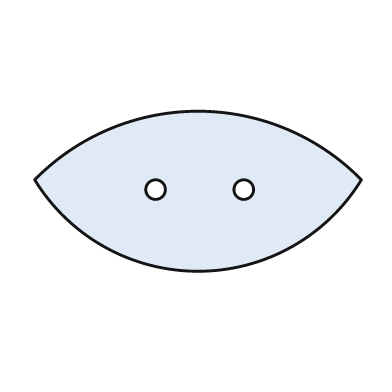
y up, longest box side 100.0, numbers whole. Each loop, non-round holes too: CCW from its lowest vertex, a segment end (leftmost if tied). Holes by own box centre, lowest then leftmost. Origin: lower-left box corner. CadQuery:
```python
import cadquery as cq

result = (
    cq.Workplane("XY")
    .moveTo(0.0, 28.0)
    .threePointArc((50.0, 0.0), (100.0, 28.0))
    .threePointArc((50.0, 49.0), (0.0, 28.0))
    .close()
    .moveTo(37.0, 25.0)
    .circle(3.0)
    .moveTo(64.0, 25.0)
    .circle(3.0)
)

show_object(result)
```